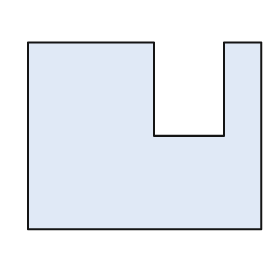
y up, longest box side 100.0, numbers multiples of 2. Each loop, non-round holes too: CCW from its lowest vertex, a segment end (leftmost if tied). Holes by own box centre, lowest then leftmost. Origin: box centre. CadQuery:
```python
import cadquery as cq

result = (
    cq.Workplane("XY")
    .moveTo(-50.0, -40.0)
    .lineTo(50.0, -40.0)
    .lineTo(50.0, 40.0)
    .lineTo(34.0, 40.0)
    .lineTo(34.0, 0.0)
    .lineTo(4.0, 0.0)
    .lineTo(4.0, 40.0)
    .lineTo(-50.0, 40.0)
    .close()
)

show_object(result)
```